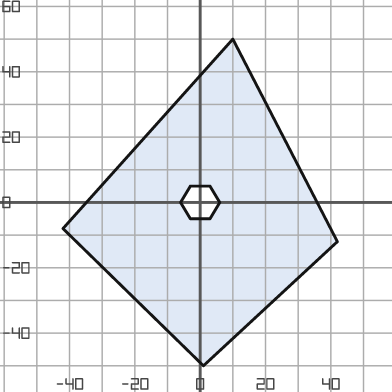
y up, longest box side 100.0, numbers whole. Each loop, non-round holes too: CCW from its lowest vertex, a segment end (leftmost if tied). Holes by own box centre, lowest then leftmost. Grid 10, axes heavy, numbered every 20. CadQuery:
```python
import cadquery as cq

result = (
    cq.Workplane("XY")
    .moveTo(1.0, -50.0)
    .lineTo(42.0, -12.0)
    .lineTo(10.0, 50.0)
    .lineTo(-42.0, -8.0)
    .close()
    .moveTo(-3.0, -5.0)
    .lineTo(3.0, -5.0)
    .lineTo(6.0, 0.0)
    .lineTo(3.0, 5.0)
    .lineTo(-3.0, 5.0)
    .lineTo(-6.0, 0.0)
    .close()
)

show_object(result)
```